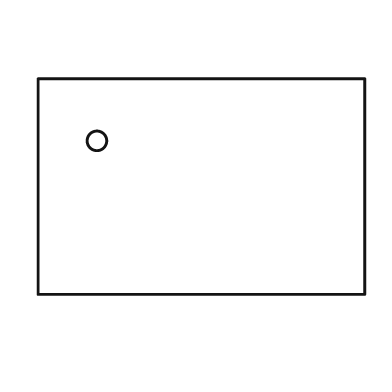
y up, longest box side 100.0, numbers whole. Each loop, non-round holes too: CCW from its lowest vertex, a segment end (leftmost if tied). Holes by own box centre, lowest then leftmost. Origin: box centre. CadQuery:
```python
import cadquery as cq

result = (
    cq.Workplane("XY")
    .moveTo(-50.0, -33.0)
    .lineTo(50.0, -33.0)
    .lineTo(50.0, 33.0)
    .lineTo(-50.0, 33.0)
    .close()
    .moveTo(-32.0, 14.0)
    .circle(3.0)
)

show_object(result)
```